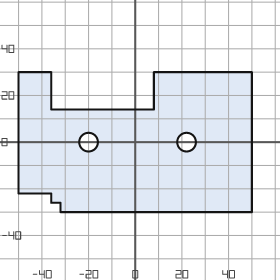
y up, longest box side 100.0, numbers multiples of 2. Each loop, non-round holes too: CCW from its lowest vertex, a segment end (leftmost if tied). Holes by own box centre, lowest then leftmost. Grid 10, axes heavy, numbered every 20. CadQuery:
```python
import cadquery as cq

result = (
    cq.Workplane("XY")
    .moveTo(-32.0, -30.0)
    .lineTo(50.0, -30.0)
    .lineTo(50.0, 30.0)
    .lineTo(8.0, 30.0)
    .lineTo(8.0, 14.0)
    .lineTo(-36.0, 14.0)
    .lineTo(-36.0, 30.0)
    .lineTo(-50.0, 30.0)
    .lineTo(-50.0, -22.0)
    .lineTo(-36.0, -22.0)
    .lineTo(-36.0, -26.0)
    .lineTo(-32.0, -26.0)
    .close()
    .moveTo(-20.0, 0.0)
    .circle(4.0)
    .moveTo(22.0, 0.0)
    .circle(4.0)
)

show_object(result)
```